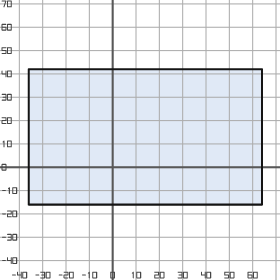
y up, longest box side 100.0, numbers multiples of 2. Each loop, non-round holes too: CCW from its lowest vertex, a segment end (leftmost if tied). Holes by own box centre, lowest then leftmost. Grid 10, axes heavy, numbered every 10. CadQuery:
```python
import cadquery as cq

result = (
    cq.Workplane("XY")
    .moveTo(-36.0, -16.0)
    .lineTo(64.0, -16.0)
    .lineTo(64.0, 42.0)
    .lineTo(-36.0, 42.0)
    .close()
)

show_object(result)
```